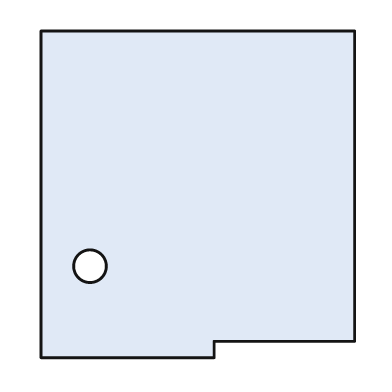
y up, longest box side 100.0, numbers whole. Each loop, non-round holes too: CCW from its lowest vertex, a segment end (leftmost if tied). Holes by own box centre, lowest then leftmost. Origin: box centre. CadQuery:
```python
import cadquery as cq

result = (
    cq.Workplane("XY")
    .moveTo(-48.0, -50.0)
    .lineTo(5.0, -50.0)
    .lineTo(5.0, -45.0)
    .lineTo(48.0, -45.0)
    .lineTo(48.0, 50.0)
    .lineTo(-48.0, 50.0)
    .close()
    .moveTo(-33.0, -22.0)
    .circle(5.0)
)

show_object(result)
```